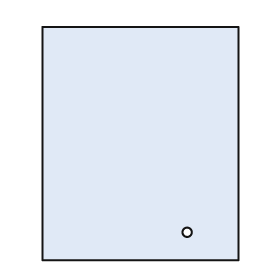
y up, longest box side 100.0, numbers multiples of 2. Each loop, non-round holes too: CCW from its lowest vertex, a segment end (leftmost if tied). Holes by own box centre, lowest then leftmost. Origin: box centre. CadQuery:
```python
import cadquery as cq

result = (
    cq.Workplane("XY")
    .moveTo(-42.0, -50.0)
    .lineTo(42.0, -50.0)
    .lineTo(42.0, 50.0)
    .lineTo(-42.0, 50.0)
    .close()
    .moveTo(20.0, -38.0)
    .circle(2.0)
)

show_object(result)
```